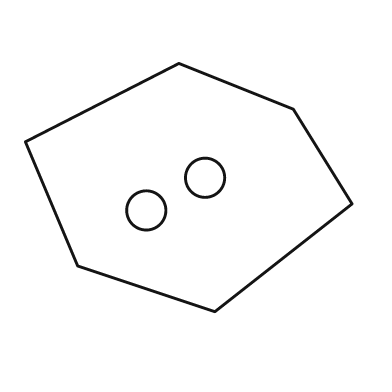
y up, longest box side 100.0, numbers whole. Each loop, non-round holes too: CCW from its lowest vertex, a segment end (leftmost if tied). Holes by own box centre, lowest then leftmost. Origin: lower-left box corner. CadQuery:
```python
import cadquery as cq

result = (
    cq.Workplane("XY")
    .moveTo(58.0, 0.0)
    .lineTo(100.0, 33.0)
    .lineTo(82.0, 62.0)
    .lineTo(47.0, 76.0)
    .lineTo(0.0, 52.0)
    .lineTo(16.0, 14.0)
    .close()
    .moveTo(37.0, 31.0)
    .circle(6.0)
    .moveTo(55.0, 41.0)
    .circle(6.0)
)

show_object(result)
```